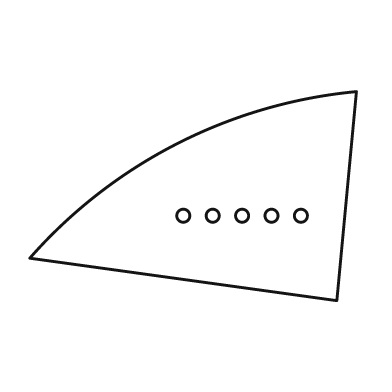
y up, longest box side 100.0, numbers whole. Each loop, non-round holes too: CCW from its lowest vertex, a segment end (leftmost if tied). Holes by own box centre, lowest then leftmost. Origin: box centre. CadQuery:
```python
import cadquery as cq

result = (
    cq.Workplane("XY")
    .moveTo(44.0, -32.0)
    .lineTo(50.0, 32.0)
    .threePointArc((-5.0, 16.0), (-50.0, -19.0))
    .close()
    .moveTo(-3.0, -6.0)
    .circle(2.0)
    .moveTo(6.0, -6.0)
    .circle(2.0)
    .moveTo(15.0, -6.0)
    .circle(2.0)
    .moveTo(24.0, -6.0)
    .circle(2.0)
    .moveTo(33.0, -6.0)
    .circle(2.0)
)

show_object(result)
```